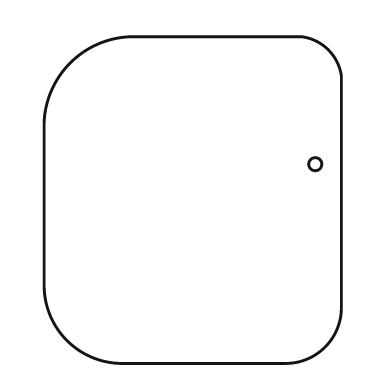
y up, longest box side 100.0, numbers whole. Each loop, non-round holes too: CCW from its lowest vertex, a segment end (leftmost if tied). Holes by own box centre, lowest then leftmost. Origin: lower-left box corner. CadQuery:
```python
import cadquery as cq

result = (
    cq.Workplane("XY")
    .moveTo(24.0, 0.0)
    .lineTo(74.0, 0.0)
    .threePointArc((86.0, 5.0), (91.0, 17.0))
    .lineTo(91.0, 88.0)
    .threePointArc((87.0, 96.0), (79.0, 100.0))
    .lineTo(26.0, 100.0)
    .threePointArc((8.0, 92.0), (0.0, 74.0))
    .lineTo(0.0, 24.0)
    .threePointArc((7.0, 7.0), (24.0, 0.0))
    .close()
    .moveTo(83.0, 61.0)
    .circle(2.0)
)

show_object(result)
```